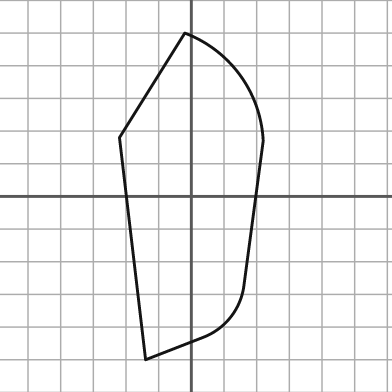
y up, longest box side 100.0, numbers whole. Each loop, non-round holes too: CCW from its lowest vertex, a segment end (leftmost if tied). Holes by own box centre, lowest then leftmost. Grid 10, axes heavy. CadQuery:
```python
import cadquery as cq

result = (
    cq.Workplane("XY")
    .moveTo(-14.0, -50.0)
    .lineTo(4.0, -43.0)
    .threePointArc((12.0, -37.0), (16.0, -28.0))
    .lineTo(22.0, 17.0)
    .threePointArc((15.0, 37.0), (-2.0, 50.0))
    .lineTo(-22.0, 18.0)
    .close()
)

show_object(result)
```